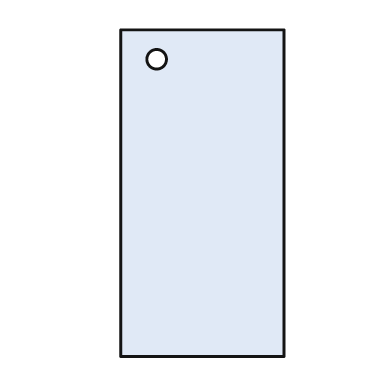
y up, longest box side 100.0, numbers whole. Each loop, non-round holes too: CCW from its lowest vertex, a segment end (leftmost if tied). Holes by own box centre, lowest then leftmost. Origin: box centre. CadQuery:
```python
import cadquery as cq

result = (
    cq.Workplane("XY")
    .moveTo(-25.0, -50.0)
    .lineTo(25.0, -50.0)
    .lineTo(25.0, 50.0)
    .lineTo(-25.0, 50.0)
    .close()
    .moveTo(-14.0, 41.0)
    .circle(3.0)
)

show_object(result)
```